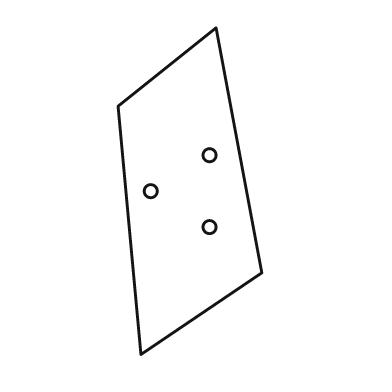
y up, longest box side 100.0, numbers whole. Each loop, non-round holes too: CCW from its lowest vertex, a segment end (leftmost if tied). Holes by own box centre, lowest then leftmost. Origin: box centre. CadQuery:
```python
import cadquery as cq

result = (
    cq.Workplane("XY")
    .moveTo(-15.0, -50.0)
    .lineTo(22.0, -25.0)
    .lineTo(8.0, 50.0)
    .lineTo(-22.0, 26.0)
    .close()
    .moveTo(6.0, -11.0)
    .circle(2.0)
    .moveTo(-12.0, 0.0)
    .circle(2.0)
    .moveTo(6.0, 11.0)
    .circle(2.0)
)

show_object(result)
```